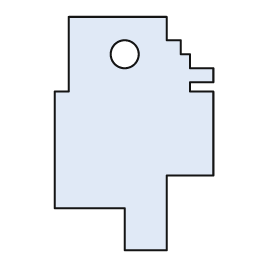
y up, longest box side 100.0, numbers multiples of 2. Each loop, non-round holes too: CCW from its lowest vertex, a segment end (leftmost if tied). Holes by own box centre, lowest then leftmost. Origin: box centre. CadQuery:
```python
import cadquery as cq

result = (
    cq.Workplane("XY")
    .moveTo(-4.0, -50.0)
    .lineTo(14.0, -50.0)
    .lineTo(14.0, -18.0)
    .lineTo(34.0, -18.0)
    .lineTo(34.0, 18.0)
    .lineTo(24.0, 18.0)
    .lineTo(24.0, 22.0)
    .lineTo(34.0, 22.0)
    .lineTo(34.0, 28.0)
    .lineTo(24.0, 28.0)
    .lineTo(24.0, 34.0)
    .lineTo(20.0, 34.0)
    .lineTo(20.0, 40.0)
    .lineTo(14.0, 40.0)
    .lineTo(14.0, 50.0)
    .lineTo(-28.0, 50.0)
    .lineTo(-28.0, 18.0)
    .lineTo(-34.0, 18.0)
    .lineTo(-34.0, -32.0)
    .lineTo(-4.0, -32.0)
    .close()
    .moveTo(-4.0, 34.0)
    .circle(6.0)
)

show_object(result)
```